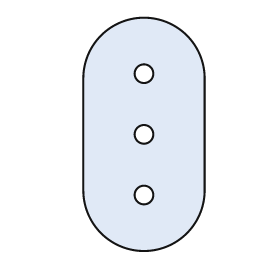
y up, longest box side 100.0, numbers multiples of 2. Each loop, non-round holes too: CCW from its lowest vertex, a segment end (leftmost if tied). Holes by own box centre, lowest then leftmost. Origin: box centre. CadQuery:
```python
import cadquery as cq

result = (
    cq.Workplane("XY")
    .moveTo(-26.0, -24.0)
    .threePointArc((0.0, -50.0), (26.0, -24.0))
    .lineTo(26.0, 24.0)
    .threePointArc((0.0, 50.0), (-26.0, 24.0))
    .close()
    .moveTo(0.0, -26.0)
    .circle(4.0)
    .moveTo(0.0, 0.0)
    .circle(4.0)
    .moveTo(0.0, 26.0)
    .circle(4.0)
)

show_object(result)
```